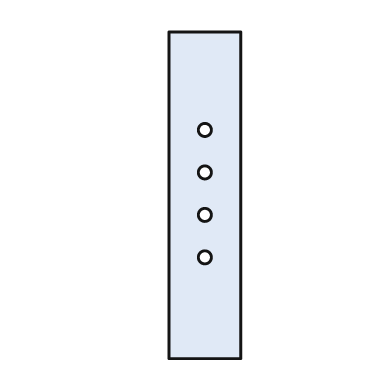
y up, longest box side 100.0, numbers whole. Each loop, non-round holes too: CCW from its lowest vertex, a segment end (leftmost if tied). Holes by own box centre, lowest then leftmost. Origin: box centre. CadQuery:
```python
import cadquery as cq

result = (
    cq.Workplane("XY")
    .moveTo(-11.0, -50.0)
    .lineTo(11.0, -50.0)
    .lineTo(11.0, 50.0)
    .lineTo(-11.0, 50.0)
    .close()
    .moveTo(0.0, -19.0)
    .circle(2.0)
    .moveTo(0.0, -6.0)
    .circle(2.0)
    .moveTo(0.0, 7.0)
    .circle(2.0)
    .moveTo(0.0, 20.0)
    .circle(2.0)
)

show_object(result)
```